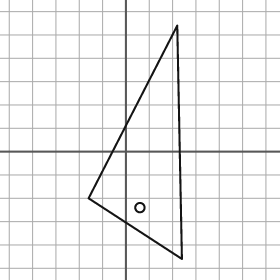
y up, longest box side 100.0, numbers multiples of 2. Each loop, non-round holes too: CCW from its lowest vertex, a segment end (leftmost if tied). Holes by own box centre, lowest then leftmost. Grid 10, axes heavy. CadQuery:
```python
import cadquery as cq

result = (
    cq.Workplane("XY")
    .moveTo(24.0, -46.0)
    .lineTo(22.0, 54.0)
    .lineTo(-16.0, -20.0)
    .close()
    .moveTo(6.0, -24.0)
    .circle(2.0)
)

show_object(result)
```